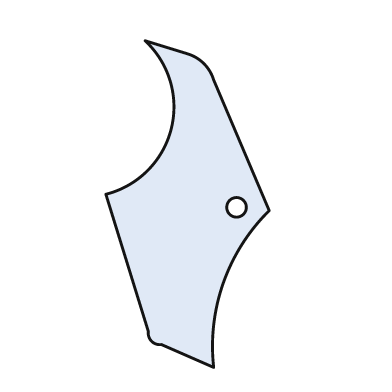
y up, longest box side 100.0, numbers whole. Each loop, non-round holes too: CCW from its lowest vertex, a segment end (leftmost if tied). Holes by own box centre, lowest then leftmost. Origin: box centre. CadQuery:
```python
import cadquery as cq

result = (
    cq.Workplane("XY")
    .moveTo(8.0, -50.0)
    .threePointArc((11.0, -24.0), (25.0, -2.0))
    .lineTo(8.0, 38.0)
    .threePointArc((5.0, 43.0), (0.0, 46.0))
    .lineTo(-13.0, 50.0)
    .threePointArc((-5.0, 23.0), (-25.0, 3.0))
    .lineTo(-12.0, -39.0)
    .threePointArc((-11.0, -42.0), (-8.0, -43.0))
    .close()
    .moveTo(15.0, -1.0)
    .circle(3.0)
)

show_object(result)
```